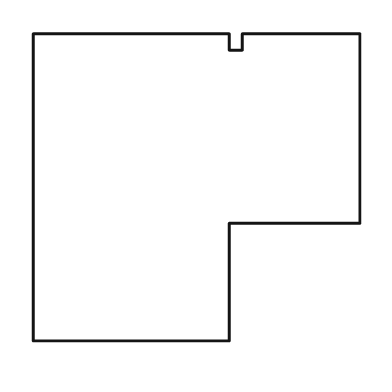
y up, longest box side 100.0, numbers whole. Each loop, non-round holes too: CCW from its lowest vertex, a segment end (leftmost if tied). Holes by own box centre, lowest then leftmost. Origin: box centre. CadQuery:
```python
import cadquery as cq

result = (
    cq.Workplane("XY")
    .moveTo(-50.0, -47.0)
    .lineTo(10.0, -47.0)
    .lineTo(10.0, -11.0)
    .lineTo(50.0, -11.0)
    .lineTo(50.0, 47.0)
    .lineTo(14.0, 47.0)
    .lineTo(14.0, 42.0)
    .lineTo(10.0, 42.0)
    .lineTo(10.0, 47.0)
    .lineTo(-50.0, 47.0)
    .close()
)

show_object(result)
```